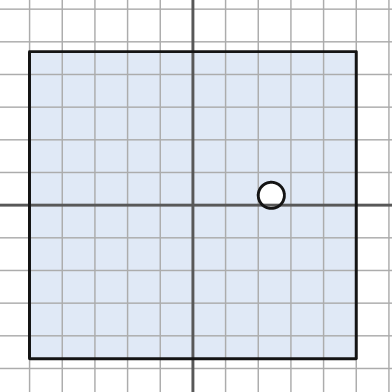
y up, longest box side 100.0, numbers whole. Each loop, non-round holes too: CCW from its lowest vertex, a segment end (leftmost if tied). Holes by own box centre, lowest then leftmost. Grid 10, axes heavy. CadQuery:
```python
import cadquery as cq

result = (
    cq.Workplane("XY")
    .moveTo(-50.0, -47.0)
    .lineTo(50.0, -47.0)
    .lineTo(50.0, 47.0)
    .lineTo(-50.0, 47.0)
    .close()
    .moveTo(24.0, 3.0)
    .circle(4.0)
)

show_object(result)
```